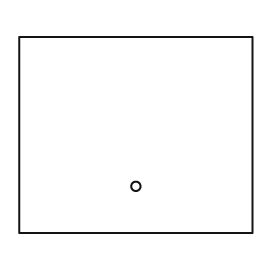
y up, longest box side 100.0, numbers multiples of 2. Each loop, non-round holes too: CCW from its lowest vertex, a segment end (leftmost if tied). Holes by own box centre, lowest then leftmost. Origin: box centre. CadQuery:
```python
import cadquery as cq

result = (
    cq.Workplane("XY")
    .moveTo(-50.0, -42.0)
    .lineTo(50.0, -42.0)
    .lineTo(50.0, 42.0)
    .lineTo(-50.0, 42.0)
    .close()
    .moveTo(0.0, -22.0)
    .circle(2.0)
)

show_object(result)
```